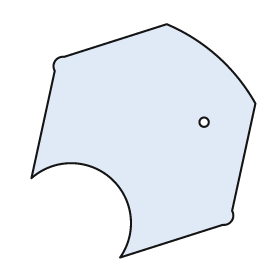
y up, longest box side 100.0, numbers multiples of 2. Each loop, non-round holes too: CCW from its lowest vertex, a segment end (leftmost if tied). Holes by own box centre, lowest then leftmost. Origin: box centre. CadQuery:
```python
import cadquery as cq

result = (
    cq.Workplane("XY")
    .moveTo(-10.0, -50.0)
    .lineTo(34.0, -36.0)
    .threePointArc((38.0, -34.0), (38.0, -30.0))
    .lineTo(48.0, 16.0)
    .threePointArc((32.0, 36.0), (10.0, 50.0))
    .lineTo(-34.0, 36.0)
    .threePointArc((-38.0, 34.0), (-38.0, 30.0))
    .lineTo(-48.0, -16.0)
    .threePointArc((-14.0, -16.0), (-10.0, -50.0))
    .close()
    .moveTo(26.0, 8.0)
    .circle(2.0)
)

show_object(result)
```